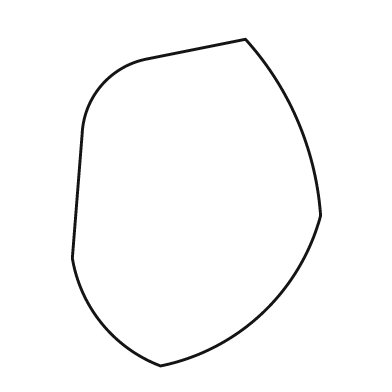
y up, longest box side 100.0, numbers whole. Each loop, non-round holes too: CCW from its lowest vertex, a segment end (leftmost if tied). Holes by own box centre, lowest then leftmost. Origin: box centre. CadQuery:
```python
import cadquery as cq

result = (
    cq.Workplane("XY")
    .moveTo(-11.0, -50.0)
    .threePointArc((20.0, -34.0), (38.0, -4.0))
    .threePointArc((31.0, 25.0), (15.0, 50.0))
    .lineTo(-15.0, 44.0)
    .threePointArc((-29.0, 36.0), (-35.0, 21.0))
    .lineTo(-38.0, -17.0)
    .threePointArc((-29.0, -37.0), (-11.0, -50.0))
    .close()
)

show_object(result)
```